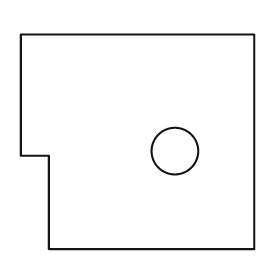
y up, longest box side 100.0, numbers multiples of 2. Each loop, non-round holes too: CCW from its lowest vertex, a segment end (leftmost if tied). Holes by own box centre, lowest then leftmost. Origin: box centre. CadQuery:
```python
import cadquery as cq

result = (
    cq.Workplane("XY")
    .moveTo(-38.0, -46.0)
    .lineTo(50.0, -46.0)
    .lineTo(50.0, 46.0)
    .lineTo(-50.0, 46.0)
    .lineTo(-50.0, -6.0)
    .lineTo(-38.0, -6.0)
    .close()
    .moveTo(16.0, -4.0)
    .circle(10.0)
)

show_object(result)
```